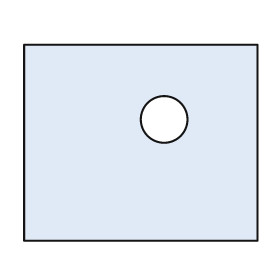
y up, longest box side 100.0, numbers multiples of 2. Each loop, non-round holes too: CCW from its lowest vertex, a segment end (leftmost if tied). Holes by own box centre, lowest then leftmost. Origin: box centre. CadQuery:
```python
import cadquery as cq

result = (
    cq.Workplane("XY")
    .moveTo(-50.0, -42.0)
    .lineTo(50.0, -42.0)
    .lineTo(50.0, 42.0)
    .lineTo(-50.0, 42.0)
    .close()
    .moveTo(10.0, 10.0)
    .circle(10.0)
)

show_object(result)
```